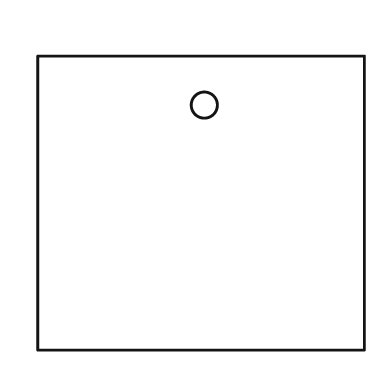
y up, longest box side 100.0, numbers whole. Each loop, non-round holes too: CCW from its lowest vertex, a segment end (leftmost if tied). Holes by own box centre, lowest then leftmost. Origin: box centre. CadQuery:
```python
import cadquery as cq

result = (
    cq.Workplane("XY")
    .moveTo(-50.0, -45.0)
    .lineTo(50.0, -45.0)
    .lineTo(50.0, 45.0)
    .lineTo(-50.0, 45.0)
    .close()
    .moveTo(1.0, 30.0)
    .circle(4.0)
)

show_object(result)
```